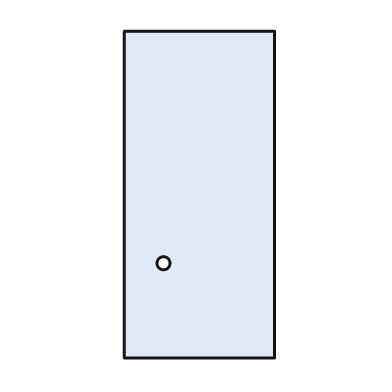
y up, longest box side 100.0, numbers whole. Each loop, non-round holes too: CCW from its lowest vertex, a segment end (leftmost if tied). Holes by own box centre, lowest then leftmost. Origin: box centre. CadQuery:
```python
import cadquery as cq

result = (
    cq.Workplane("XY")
    .moveTo(-23.0, -50.0)
    .lineTo(23.0, -50.0)
    .lineTo(23.0, 50.0)
    .lineTo(-23.0, 50.0)
    .close()
    .moveTo(-11.0, -21.0)
    .circle(2.0)
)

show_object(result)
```